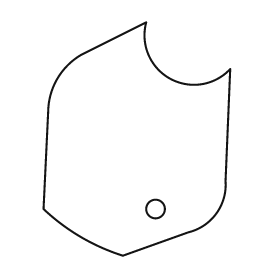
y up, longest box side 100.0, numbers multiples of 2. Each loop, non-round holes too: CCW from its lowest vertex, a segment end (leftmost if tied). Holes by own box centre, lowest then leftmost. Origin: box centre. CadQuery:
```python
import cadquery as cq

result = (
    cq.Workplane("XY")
    .moveTo(-6.0, -50.0)
    .lineTo(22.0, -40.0)
    .threePointArc((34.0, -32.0), (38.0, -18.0))
    .lineTo(40.0, 30.0)
    .threePointArc((14.0, 26.0), (4.0, 50.0))
    .lineTo(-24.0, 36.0)
    .threePointArc((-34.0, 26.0), (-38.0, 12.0))
    .lineTo(-40.0, -30.0)
    .threePointArc((-24.0, -42.0), (-6.0, -50.0))
    .close()
    .moveTo(8.0, -30.0)
    .circle(4.0)
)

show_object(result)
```